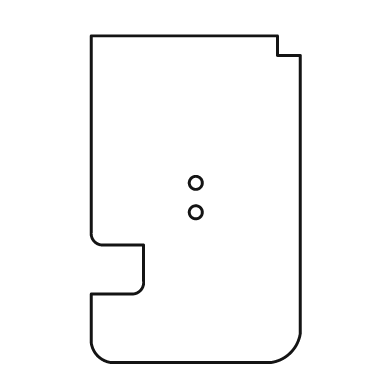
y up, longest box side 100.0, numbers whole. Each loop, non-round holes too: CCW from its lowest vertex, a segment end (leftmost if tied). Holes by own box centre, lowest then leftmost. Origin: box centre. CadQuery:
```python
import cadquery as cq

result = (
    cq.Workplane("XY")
    .moveTo(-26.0, -50.0)
    .lineTo(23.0, -50.0)
    .threePointArc((29.0, -47.0), (32.0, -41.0))
    .lineTo(32.0, 44.0)
    .lineTo(25.0, 44.0)
    .lineTo(25.0, 50.0)
    .lineTo(-32.0, 50.0)
    .lineTo(-32.0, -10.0)
    .threePointArc((-31.0, -13.0), (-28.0, -14.0))
    .lineTo(-16.0, -14.0)
    .lineTo(-16.0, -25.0)
    .threePointArc((-17.0, -28.0), (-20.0, -29.0))
    .lineTo(-32.0, -29.0)
    .lineTo(-32.0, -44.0)
    .threePointArc((-30.0, -48.0), (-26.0, -50.0))
    .close()
    .moveTo(0.0, -4.0)
    .circle(2.0)
    .moveTo(0.0, 5.0)
    .circle(2.0)
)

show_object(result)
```